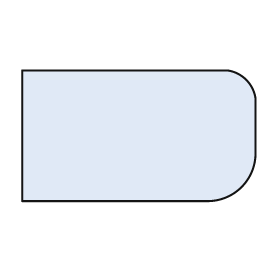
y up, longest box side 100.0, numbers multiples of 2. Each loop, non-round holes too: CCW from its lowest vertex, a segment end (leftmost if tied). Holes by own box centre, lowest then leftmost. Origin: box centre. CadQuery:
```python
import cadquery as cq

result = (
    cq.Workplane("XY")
    .moveTo(-50.0, -28.0)
    .lineTo(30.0, -28.0)
    .threePointArc((44.0, -22.0), (50.0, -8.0))
    .lineTo(50.0, 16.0)
    .threePointArc((46.0, 24.0), (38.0, 28.0))
    .lineTo(-50.0, 28.0)
    .close()
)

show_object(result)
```